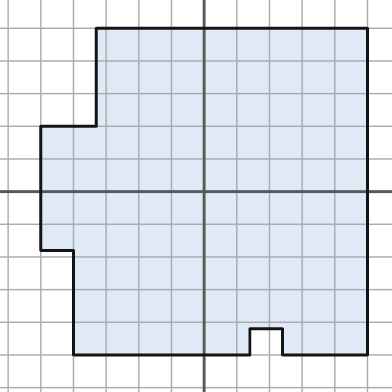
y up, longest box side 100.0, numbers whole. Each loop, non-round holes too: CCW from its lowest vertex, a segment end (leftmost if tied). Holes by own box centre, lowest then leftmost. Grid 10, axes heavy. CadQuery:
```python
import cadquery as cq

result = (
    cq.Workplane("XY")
    .moveTo(-40.0, -50.0)
    .lineTo(14.0, -50.0)
    .lineTo(14.0, -42.0)
    .lineTo(24.0, -42.0)
    .lineTo(24.0, -50.0)
    .lineTo(50.0, -50.0)
    .lineTo(50.0, 50.0)
    .lineTo(-33.0, 50.0)
    .lineTo(-33.0, 20.0)
    .lineTo(-50.0, 20.0)
    .lineTo(-50.0, -18.0)
    .lineTo(-40.0, -18.0)
    .close()
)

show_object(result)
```